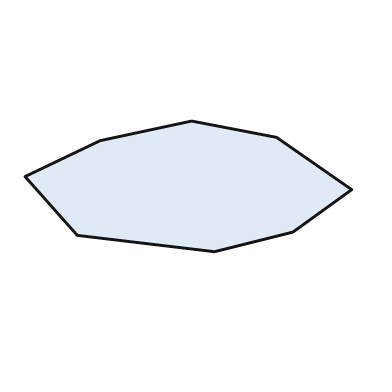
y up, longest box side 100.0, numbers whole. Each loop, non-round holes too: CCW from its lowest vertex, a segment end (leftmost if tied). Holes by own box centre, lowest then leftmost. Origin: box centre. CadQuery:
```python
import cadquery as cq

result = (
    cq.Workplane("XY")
    .moveTo(8.0, -20.0)
    .lineTo(32.0, -14.0)
    .lineTo(50.0, -1.0)
    .lineTo(27.0, 15.0)
    .lineTo(1.0, 20.0)
    .lineTo(-27.0, 14.0)
    .lineTo(-50.0, 3.0)
    .lineTo(-34.0, -15.0)
    .close()
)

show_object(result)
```